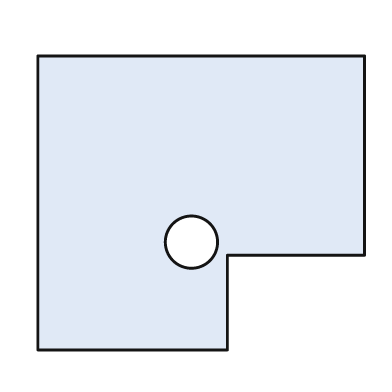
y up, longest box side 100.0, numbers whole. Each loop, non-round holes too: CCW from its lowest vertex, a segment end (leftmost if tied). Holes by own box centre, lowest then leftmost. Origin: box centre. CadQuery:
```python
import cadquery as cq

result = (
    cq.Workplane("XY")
    .moveTo(-50.0, -45.0)
    .lineTo(8.0, -45.0)
    .lineTo(8.0, -16.0)
    .lineTo(50.0, -16.0)
    .lineTo(50.0, 45.0)
    .lineTo(-50.0, 45.0)
    .close()
    .moveTo(-3.0, -12.0)
    .circle(8.0)
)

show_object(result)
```